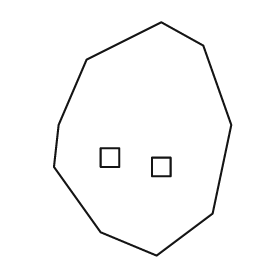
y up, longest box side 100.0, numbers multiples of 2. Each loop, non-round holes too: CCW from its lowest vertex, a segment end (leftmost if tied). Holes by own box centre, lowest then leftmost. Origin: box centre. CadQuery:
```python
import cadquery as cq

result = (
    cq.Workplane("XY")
    .moveTo(6.0, -50.0)
    .lineTo(30.0, -32.0)
    .lineTo(38.0, 6.0)
    .lineTo(26.0, 40.0)
    .lineTo(8.0, 50.0)
    .lineTo(-24.0, 34.0)
    .lineTo(-36.0, 6.0)
    .lineTo(-38.0, -12.0)
    .lineTo(-18.0, -40.0)
    .close()
    .moveTo(4.0, -16.0)
    .lineTo(12.0, -16.0)
    .lineTo(12.0, -8.0)
    .lineTo(4.0, -8.0)
    .close()
    .moveTo(-18.0, -12.0)
    .lineTo(-10.0, -12.0)
    .lineTo(-10.0, -4.0)
    .lineTo(-18.0, -4.0)
    .close()
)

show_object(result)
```